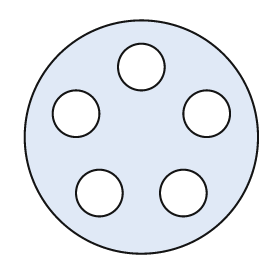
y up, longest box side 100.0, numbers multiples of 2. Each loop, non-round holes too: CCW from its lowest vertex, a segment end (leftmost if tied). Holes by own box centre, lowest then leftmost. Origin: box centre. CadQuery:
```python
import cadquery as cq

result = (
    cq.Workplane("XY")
    .moveTo(0.0, 0.0)
    .circle(50.0)
    .moveTo(-18.0, -24.0)
    .circle(10.0)
    .moveTo(18.0, -24.0)
    .circle(10.0)
    .moveTo(-28.0, 10.0)
    .circle(10.0)
    .moveTo(28.0, 10.0)
    .circle(10.0)
    .moveTo(0.0, 30.0)
    .circle(10.0)
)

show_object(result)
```